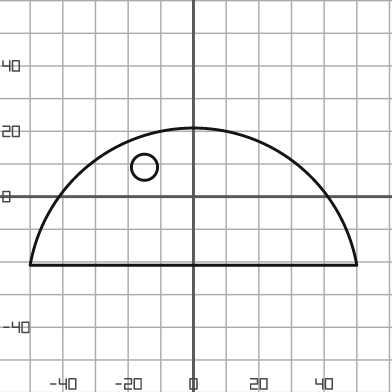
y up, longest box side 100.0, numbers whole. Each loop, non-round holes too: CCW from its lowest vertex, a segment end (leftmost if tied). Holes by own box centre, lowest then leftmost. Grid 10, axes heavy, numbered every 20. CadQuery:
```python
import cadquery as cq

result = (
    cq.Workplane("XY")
    .moveTo(-50.0, -21.0)
    .lineTo(50.0, -21.0)
    .threePointArc((0.0, 21.0), (-50.0, -21.0))
    .close()
    .moveTo(-15.0, 9.0)
    .circle(4.0)
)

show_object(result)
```